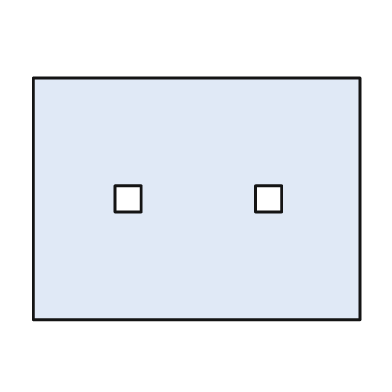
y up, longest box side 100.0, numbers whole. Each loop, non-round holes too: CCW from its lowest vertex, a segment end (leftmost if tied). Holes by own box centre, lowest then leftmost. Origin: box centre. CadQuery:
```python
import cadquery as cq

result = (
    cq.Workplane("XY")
    .moveTo(-50.0, -37.0)
    .lineTo(50.0, -37.0)
    .lineTo(50.0, 37.0)
    .lineTo(-50.0, 37.0)
    .close()
    .moveTo(-25.0, -4.0)
    .lineTo(-17.0, -4.0)
    .lineTo(-17.0, 4.0)
    .lineTo(-25.0, 4.0)
    .close()
    .moveTo(18.0, -4.0)
    .lineTo(26.0, -4.0)
    .lineTo(26.0, 4.0)
    .lineTo(18.0, 4.0)
    .close()
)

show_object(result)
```